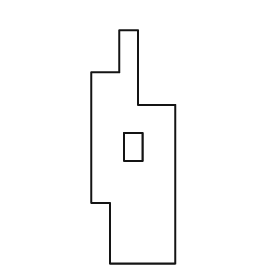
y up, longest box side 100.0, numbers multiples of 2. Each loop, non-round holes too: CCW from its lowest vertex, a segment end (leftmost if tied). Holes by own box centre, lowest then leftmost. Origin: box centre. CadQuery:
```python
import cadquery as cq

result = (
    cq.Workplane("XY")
    .moveTo(-10.0, -50.0)
    .lineTo(18.0, -50.0)
    .lineTo(18.0, 18.0)
    .lineTo(2.0, 18.0)
    .lineTo(2.0, 50.0)
    .lineTo(-6.0, 50.0)
    .lineTo(-6.0, 32.0)
    .lineTo(-18.0, 32.0)
    .lineTo(-18.0, -24.0)
    .lineTo(-10.0, -24.0)
    .close()
    .moveTo(-4.0, -6.0)
    .lineTo(4.0, -6.0)
    .lineTo(4.0, 6.0)
    .lineTo(-4.0, 6.0)
    .close()
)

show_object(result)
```